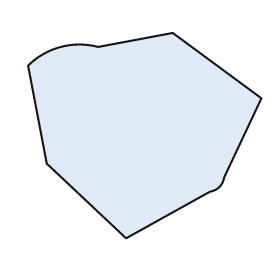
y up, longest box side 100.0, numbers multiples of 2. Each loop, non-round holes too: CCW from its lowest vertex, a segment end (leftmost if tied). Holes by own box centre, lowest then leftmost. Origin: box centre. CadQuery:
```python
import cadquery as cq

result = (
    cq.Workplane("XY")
    .moveTo(-8.0, -44.0)
    .lineTo(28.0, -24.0)
    .threePointArc((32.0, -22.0), (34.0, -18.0))
    .lineTo(50.0, 16.0)
    .lineTo(12.0, 44.0)
    .lineTo(-20.0, 38.0)
    .threePointArc((-36.0, 38.0), (-50.0, 30.0))
    .lineTo(-42.0, -12.0)
    .close()
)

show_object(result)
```